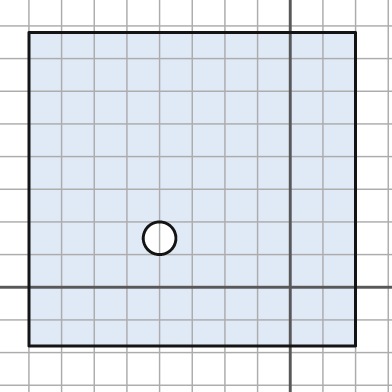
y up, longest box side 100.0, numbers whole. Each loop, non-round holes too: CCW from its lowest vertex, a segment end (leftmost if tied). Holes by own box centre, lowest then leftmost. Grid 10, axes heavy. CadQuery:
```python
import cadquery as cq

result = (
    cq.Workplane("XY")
    .moveTo(-80.0, -18.0)
    .lineTo(20.0, -18.0)
    .lineTo(20.0, 78.0)
    .lineTo(-80.0, 78.0)
    .close()
    .moveTo(-40.0, 15.0)
    .circle(5.0)
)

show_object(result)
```